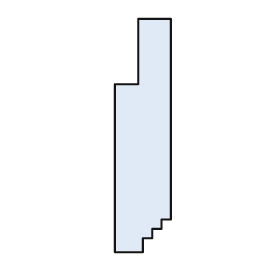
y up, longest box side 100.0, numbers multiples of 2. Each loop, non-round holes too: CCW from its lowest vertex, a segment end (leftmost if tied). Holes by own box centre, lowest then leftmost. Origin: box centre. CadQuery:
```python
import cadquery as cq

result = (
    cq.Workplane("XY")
    .moveTo(-12.0, -50.0)
    .lineTo(0.0, -50.0)
    .lineTo(0.0, -44.0)
    .lineTo(4.0, -44.0)
    .lineTo(4.0, -40.0)
    .lineTo(8.0, -40.0)
    .lineTo(8.0, -36.0)
    .lineTo(12.0, -36.0)
    .lineTo(12.0, 50.0)
    .lineTo(-2.0, 50.0)
    .lineTo(-2.0, 22.0)
    .lineTo(-12.0, 22.0)
    .close()
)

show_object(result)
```